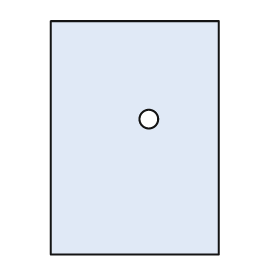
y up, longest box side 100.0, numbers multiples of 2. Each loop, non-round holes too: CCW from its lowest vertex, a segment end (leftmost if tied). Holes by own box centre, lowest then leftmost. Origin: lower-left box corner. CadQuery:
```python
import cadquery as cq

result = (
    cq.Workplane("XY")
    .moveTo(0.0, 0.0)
    .lineTo(72.0, 0.0)
    .lineTo(72.0, 100.0)
    .lineTo(0.0, 100.0)
    .close()
    .moveTo(42.0, 58.0)
    .circle(4.0)
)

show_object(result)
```